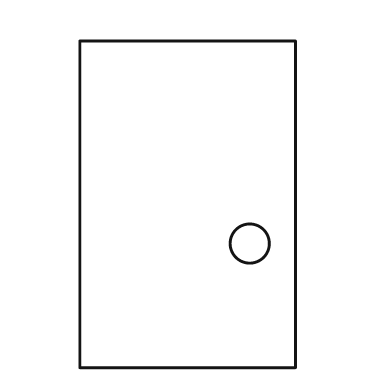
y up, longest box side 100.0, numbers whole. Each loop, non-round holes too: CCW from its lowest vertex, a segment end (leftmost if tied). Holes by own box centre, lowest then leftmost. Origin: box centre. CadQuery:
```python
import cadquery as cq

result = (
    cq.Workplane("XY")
    .moveTo(-33.0, -50.0)
    .lineTo(33.0, -50.0)
    .lineTo(33.0, 50.0)
    .lineTo(-33.0, 50.0)
    .close()
    .moveTo(19.0, -12.0)
    .circle(6.0)
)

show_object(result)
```